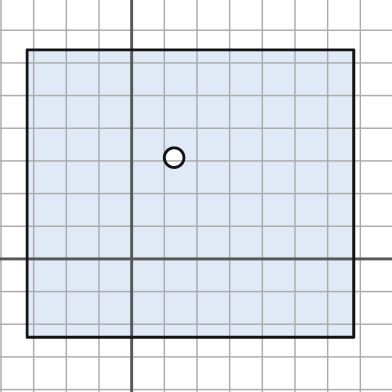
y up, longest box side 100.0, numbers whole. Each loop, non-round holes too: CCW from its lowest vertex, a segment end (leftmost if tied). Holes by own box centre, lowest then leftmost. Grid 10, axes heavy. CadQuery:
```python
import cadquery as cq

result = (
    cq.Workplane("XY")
    .moveTo(-32.0, -24.0)
    .lineTo(68.0, -24.0)
    .lineTo(68.0, 64.0)
    .lineTo(-32.0, 64.0)
    .close()
    .moveTo(13.0, 31.0)
    .circle(3.0)
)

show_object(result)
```